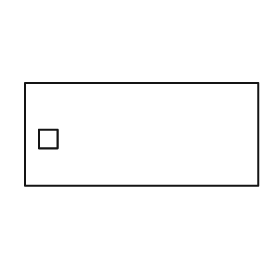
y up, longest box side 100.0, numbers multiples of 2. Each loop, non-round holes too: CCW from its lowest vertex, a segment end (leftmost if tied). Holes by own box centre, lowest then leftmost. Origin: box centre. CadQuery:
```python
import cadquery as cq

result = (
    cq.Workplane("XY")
    .moveTo(-50.0, -22.0)
    .lineTo(50.0, -22.0)
    .lineTo(50.0, 22.0)
    .lineTo(-50.0, 22.0)
    .close()
    .moveTo(-44.0, -6.0)
    .lineTo(-36.0, -6.0)
    .lineTo(-36.0, 2.0)
    .lineTo(-44.0, 2.0)
    .close()
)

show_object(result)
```